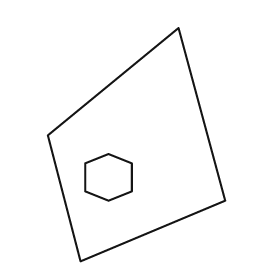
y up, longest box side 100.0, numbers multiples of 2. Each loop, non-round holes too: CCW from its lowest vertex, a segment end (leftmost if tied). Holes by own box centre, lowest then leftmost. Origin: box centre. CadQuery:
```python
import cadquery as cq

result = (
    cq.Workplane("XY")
    .moveTo(-24.0, -50.0)
    .lineTo(38.0, -24.0)
    .lineTo(18.0, 50.0)
    .lineTo(-38.0, 4.0)
    .close()
    .moveTo(-12.0, -24.0)
    .lineTo(-2.0, -20.0)
    .lineTo(-2.0, -8.0)
    .lineTo(-12.0, -4.0)
    .lineTo(-22.0, -8.0)
    .lineTo(-22.0, -20.0)
    .close()
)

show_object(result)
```